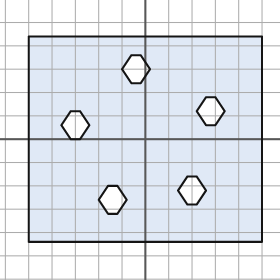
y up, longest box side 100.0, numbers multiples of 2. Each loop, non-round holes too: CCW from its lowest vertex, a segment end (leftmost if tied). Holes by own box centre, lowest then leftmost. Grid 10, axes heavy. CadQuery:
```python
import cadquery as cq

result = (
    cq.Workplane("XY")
    .moveTo(-50.0, -44.0)
    .lineTo(50.0, -44.0)
    .lineTo(50.0, 44.0)
    .lineTo(-50.0, 44.0)
    .close()
    .moveTo(-16.0, -32.0)
    .lineTo(-12.0, -32.0)
    .lineTo(-8.0, -26.0)
    .lineTo(-12.0, -20.0)
    .lineTo(-16.0, -20.0)
    .lineTo(-20.0, -26.0)
    .close()
    .moveTo(18.0, -28.0)
    .lineTo(22.0, -28.0)
    .lineTo(26.0, -22.0)
    .lineTo(22.0, -16.0)
    .lineTo(18.0, -16.0)
    .lineTo(14.0, -22.0)
    .close()
    .moveTo(-32.0, 0.0)
    .lineTo(-28.0, 0.0)
    .lineTo(-24.0, 6.0)
    .lineTo(-28.0, 12.0)
    .lineTo(-32.0, 12.0)
    .lineTo(-36.0, 6.0)
    .close()
    .moveTo(26.0, 6.0)
    .lineTo(30.0, 6.0)
    .lineTo(34.0, 12.0)
    .lineTo(30.0, 18.0)
    .lineTo(26.0, 18.0)
    .lineTo(22.0, 12.0)
    .close()
    .moveTo(-6.0, 24.0)
    .lineTo(-2.0, 24.0)
    .lineTo(2.0, 30.0)
    .lineTo(-2.0, 36.0)
    .lineTo(-6.0, 36.0)
    .lineTo(-10.0, 30.0)
    .close()
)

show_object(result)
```